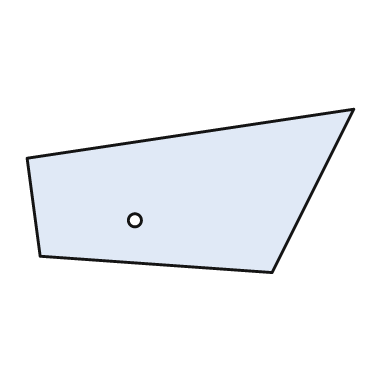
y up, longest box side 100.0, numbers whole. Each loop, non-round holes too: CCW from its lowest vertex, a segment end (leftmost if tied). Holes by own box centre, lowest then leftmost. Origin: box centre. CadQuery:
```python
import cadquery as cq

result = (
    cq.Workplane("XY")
    .moveTo(25.0, -25.0)
    .lineTo(50.0, 25.0)
    .lineTo(-50.0, 10.0)
    .lineTo(-46.0, -20.0)
    .close()
    .moveTo(-17.0, -9.0)
    .circle(2.0)
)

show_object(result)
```